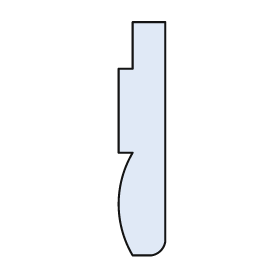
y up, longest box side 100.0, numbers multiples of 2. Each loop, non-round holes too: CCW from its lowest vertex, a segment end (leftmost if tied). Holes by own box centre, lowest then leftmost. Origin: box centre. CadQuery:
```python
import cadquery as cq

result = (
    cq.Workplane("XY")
    .moveTo(-4.0, -50.0)
    .lineTo(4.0, -50.0)
    .threePointArc((8.0, -48.0), (10.0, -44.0))
    .lineTo(10.0, 50.0)
    .lineTo(-4.0, 50.0)
    .lineTo(-4.0, 30.0)
    .lineTo(-10.0, 30.0)
    .lineTo(-10.0, -6.0)
    .lineTo(-4.0, -6.0)
    .threePointArc((-10.0, -28.0), (-4.0, -50.0))
    .close()
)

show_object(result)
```